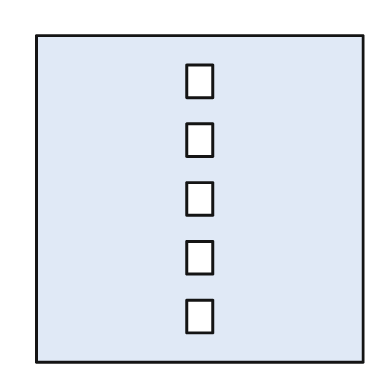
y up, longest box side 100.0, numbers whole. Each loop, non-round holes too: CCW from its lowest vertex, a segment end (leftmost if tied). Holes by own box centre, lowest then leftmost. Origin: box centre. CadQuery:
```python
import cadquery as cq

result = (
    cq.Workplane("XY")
    .moveTo(-50.0, -50.0)
    .lineTo(50.0, -50.0)
    .lineTo(50.0, 50.0)
    .lineTo(-50.0, 50.0)
    .close()
    .moveTo(-4.0, -41.0)
    .lineTo(4.0, -41.0)
    .lineTo(4.0, -31.0)
    .lineTo(-4.0, -31.0)
    .close()
    .moveTo(-4.0, -23.0)
    .lineTo(4.0, -23.0)
    .lineTo(4.0, -13.0)
    .lineTo(-4.0, -13.0)
    .close()
    .moveTo(-4.0, -5.0)
    .lineTo(4.0, -5.0)
    .lineTo(4.0, 5.0)
    .lineTo(-4.0, 5.0)
    .close()
    .moveTo(-4.0, 13.0)
    .lineTo(4.0, 13.0)
    .lineTo(4.0, 23.0)
    .lineTo(-4.0, 23.0)
    .close()
    .moveTo(-4.0, 31.0)
    .lineTo(4.0, 31.0)
    .lineTo(4.0, 41.0)
    .lineTo(-4.0, 41.0)
    .close()
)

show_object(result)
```